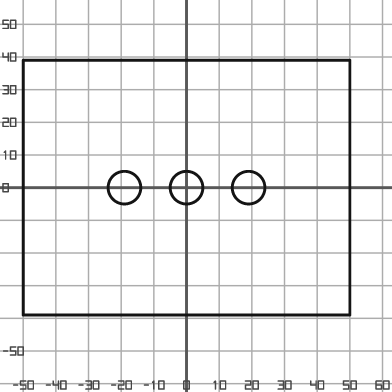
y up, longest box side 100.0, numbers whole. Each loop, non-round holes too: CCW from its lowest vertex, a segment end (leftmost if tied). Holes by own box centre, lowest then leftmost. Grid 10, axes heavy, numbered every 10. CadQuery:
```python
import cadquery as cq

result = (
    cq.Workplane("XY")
    .moveTo(-50.0, -39.0)
    .lineTo(50.0, -39.0)
    .lineTo(50.0, 39.0)
    .lineTo(-50.0, 39.0)
    .close()
    .moveTo(-19.0, 0.0)
    .circle(5.0)
    .moveTo(0.0, 0.0)
    .circle(5.0)
    .moveTo(19.0, 0.0)
    .circle(5.0)
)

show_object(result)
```